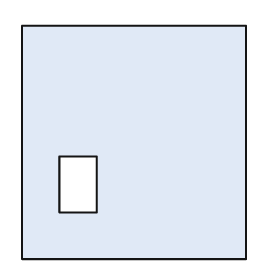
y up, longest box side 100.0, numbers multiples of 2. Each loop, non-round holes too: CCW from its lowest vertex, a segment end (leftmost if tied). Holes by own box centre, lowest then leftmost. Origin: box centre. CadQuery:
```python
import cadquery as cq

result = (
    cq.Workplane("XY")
    .moveTo(-48.0, -50.0)
    .lineTo(48.0, -50.0)
    .lineTo(48.0, 50.0)
    .lineTo(-48.0, 50.0)
    .close()
    .moveTo(-32.0, -30.0)
    .lineTo(-16.0, -30.0)
    .lineTo(-16.0, -6.0)
    .lineTo(-32.0, -6.0)
    .close()
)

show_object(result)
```